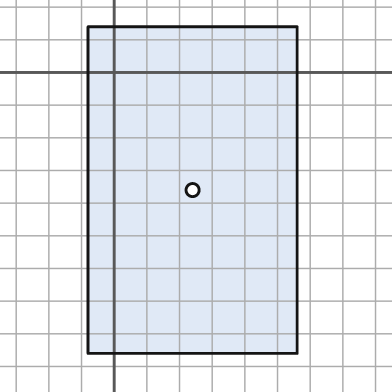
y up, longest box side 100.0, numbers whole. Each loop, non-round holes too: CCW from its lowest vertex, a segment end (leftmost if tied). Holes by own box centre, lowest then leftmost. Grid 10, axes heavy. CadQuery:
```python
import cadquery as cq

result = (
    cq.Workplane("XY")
    .moveTo(-8.0, -86.0)
    .lineTo(56.0, -86.0)
    .lineTo(56.0, 14.0)
    .lineTo(-8.0, 14.0)
    .close()
    .moveTo(24.0, -36.0)
    .circle(2.0)
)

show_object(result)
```